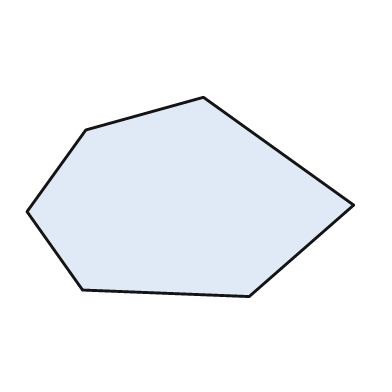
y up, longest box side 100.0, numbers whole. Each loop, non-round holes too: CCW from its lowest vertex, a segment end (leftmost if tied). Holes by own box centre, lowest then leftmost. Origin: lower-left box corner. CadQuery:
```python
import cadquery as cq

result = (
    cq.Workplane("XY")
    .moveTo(68.0, 0.0)
    .lineTo(100.0, 28.0)
    .lineTo(54.0, 61.0)
    .lineTo(18.0, 51.0)
    .lineTo(0.0, 26.0)
    .lineTo(17.0, 2.0)
    .close()
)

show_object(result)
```